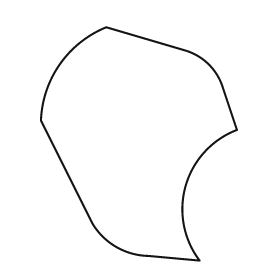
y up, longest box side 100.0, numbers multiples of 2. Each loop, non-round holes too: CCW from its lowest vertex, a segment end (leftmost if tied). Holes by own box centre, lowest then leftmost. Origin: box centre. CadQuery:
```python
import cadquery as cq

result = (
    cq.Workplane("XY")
    .moveTo(26.0, -50.0)
    .threePointArc((20.0, -18.0), (42.0, 6.0))
    .lineTo(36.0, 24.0)
    .threePointArc((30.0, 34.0), (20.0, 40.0))
    .lineTo(-14.0, 50.0)
    .threePointArc((-34.0, 34.0), (-42.0, 10.0))
    .lineTo(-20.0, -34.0)
    .threePointArc((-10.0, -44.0), (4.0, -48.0))
    .close()
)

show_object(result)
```